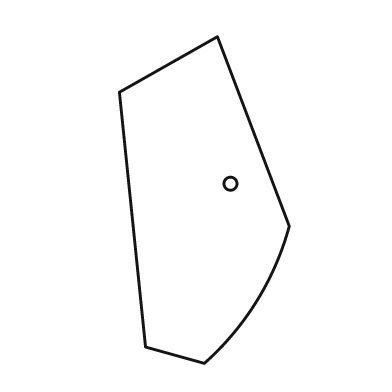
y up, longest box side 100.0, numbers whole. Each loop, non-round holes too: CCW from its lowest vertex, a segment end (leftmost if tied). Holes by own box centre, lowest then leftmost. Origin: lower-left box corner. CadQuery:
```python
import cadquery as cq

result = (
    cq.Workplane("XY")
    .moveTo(26.0, 0.0)
    .threePointArc((42.0, 19.0), (52.0, 42.0))
    .lineTo(30.0, 100.0)
    .lineTo(0.0, 83.0)
    .lineTo(8.0, 5.0)
    .close()
    .moveTo(34.0, 55.0)
    .circle(2.0)
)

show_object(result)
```